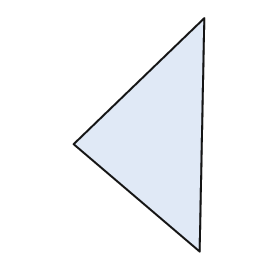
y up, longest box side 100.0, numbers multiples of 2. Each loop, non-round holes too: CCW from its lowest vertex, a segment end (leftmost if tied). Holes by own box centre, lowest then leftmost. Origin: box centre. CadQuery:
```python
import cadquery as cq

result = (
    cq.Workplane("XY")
    .moveTo(26.0, -50.0)
    .lineTo(28.0, 50.0)
    .lineTo(-28.0, -4.0)
    .close()
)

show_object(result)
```